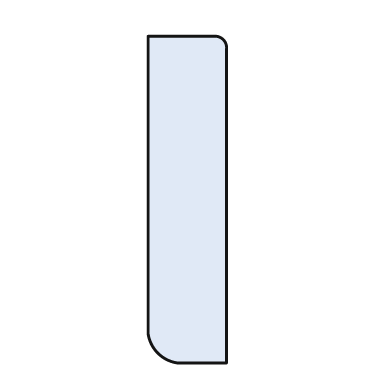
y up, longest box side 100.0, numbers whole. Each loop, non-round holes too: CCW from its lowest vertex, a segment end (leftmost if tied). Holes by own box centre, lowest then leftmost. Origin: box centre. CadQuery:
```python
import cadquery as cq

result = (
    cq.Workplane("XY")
    .moveTo(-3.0, -50.0)
    .lineTo(12.0, -50.0)
    .lineTo(12.0, 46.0)
    .threePointArc((11.0, 49.0), (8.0, 50.0))
    .lineTo(-12.0, 50.0)
    .lineTo(-12.0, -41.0)
    .threePointArc((-9.0, -47.0), (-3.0, -50.0))
    .close()
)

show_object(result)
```